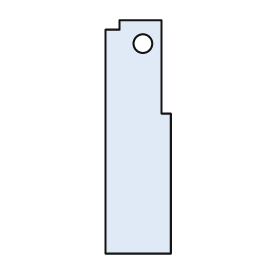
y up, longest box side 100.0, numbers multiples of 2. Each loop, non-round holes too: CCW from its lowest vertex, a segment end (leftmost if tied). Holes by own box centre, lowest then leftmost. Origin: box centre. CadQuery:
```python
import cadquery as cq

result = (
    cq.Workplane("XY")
    .moveTo(-14.0, -50.0)
    .lineTo(14.0, -50.0)
    .lineTo(14.0, 10.0)
    .lineTo(10.0, 10.0)
    .lineTo(10.0, 50.0)
    .lineTo(-8.0, 50.0)
    .lineTo(-8.0, 46.0)
    .lineTo(-14.0, 46.0)
    .close()
    .moveTo(2.0, 40.0)
    .circle(4.0)
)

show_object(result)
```